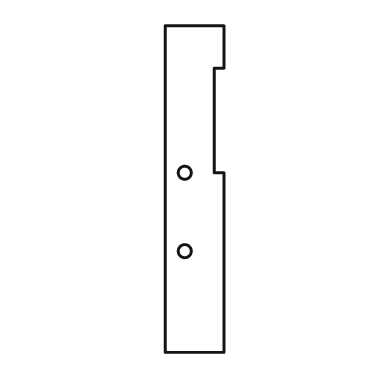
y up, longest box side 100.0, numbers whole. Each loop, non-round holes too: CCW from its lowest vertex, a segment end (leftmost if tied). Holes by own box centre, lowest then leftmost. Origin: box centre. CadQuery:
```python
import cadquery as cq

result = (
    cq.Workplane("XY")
    .moveTo(-9.0, -50.0)
    .lineTo(9.0, -50.0)
    .lineTo(9.0, 5.0)
    .lineTo(6.0, 5.0)
    .lineTo(6.0, 37.0)
    .lineTo(9.0, 37.0)
    .lineTo(9.0, 50.0)
    .lineTo(-9.0, 50.0)
    .close()
    .moveTo(-3.0, -19.0)
    .circle(2.0)
    .moveTo(-3.0, 5.0)
    .circle(2.0)
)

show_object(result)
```